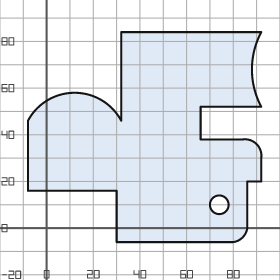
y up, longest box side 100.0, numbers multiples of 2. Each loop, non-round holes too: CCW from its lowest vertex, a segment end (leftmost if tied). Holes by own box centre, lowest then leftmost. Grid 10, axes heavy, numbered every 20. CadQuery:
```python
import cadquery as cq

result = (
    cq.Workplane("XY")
    .moveTo(30.0, -6.0)
    .lineTo(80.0, -6.0)
    .threePointArc((84.0, -4.0), (86.0, 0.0))
    .lineTo(86.0, 20.0)
    .lineTo(92.0, 20.0)
    .lineTo(92.0, 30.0)
    .threePointArc((90.0, 36.0), (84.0, 38.0))
    .lineTo(66.0, 38.0)
    .lineTo(66.0, 52.0)
    .lineTo(92.0, 52.0)
    .threePointArc((88.0, 68.0), (92.0, 84.0))
    .lineTo(32.0, 84.0)
    .lineTo(32.0, 46.0)
    .threePointArc((12.0, 58.0), (-8.0, 46.0))
    .lineTo(-8.0, 16.0)
    .lineTo(30.0, 16.0)
    .close()
    .moveTo(74.0, 10.0)
    .circle(4.0)
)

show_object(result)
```